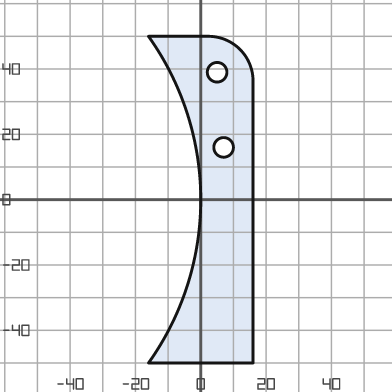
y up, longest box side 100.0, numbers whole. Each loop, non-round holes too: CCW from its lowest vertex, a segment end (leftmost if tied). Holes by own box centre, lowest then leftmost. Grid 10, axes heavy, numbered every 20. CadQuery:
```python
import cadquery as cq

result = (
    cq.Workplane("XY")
    .moveTo(-16.0, -50.0)
    .lineTo(16.0, -50.0)
    .lineTo(16.0, 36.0)
    .threePointArc((12.0, 46.0), (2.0, 50.0))
    .lineTo(-16.0, 50.0)
    .threePointArc((0.0, 0.0), (-16.0, -50.0))
    .close()
    .moveTo(7.0, 16.0)
    .circle(3.0)
    .moveTo(5.0, 39.0)
    .circle(3.0)
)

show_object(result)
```